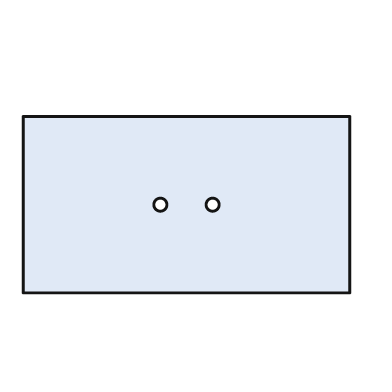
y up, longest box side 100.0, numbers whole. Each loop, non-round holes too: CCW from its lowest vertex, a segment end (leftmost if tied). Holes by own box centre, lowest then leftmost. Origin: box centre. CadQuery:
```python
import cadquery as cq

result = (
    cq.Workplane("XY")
    .moveTo(-50.0, -27.0)
    .lineTo(50.0, -27.0)
    .lineTo(50.0, 27.0)
    .lineTo(-50.0, 27.0)
    .close()
    .moveTo(-8.0, 0.0)
    .circle(2.0)
    .moveTo(8.0, 0.0)
    .circle(2.0)
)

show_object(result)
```